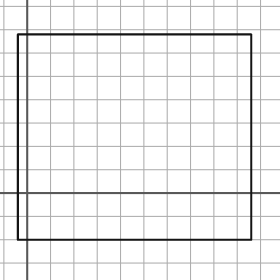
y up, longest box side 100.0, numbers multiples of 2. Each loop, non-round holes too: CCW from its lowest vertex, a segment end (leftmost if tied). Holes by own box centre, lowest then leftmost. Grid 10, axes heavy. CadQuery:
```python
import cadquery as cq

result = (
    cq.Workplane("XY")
    .moveTo(-4.0, -20.0)
    .lineTo(96.0, -20.0)
    .lineTo(96.0, 68.0)
    .lineTo(-4.0, 68.0)
    .close()
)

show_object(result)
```